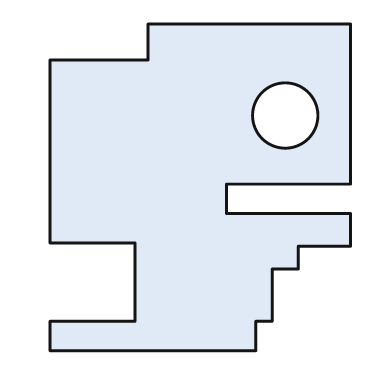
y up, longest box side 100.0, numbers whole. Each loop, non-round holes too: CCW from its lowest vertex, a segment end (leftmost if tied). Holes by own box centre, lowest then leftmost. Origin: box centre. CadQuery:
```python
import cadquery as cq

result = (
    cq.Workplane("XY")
    .moveTo(-46.0, -50.0)
    .lineTo(17.0, -50.0)
    .lineTo(17.0, -41.0)
    .lineTo(22.0, -41.0)
    .lineTo(22.0, -25.0)
    .lineTo(30.0, -25.0)
    .lineTo(30.0, -18.0)
    .lineTo(46.0, -18.0)
    .lineTo(46.0, -8.0)
    .lineTo(8.0, -8.0)
    .lineTo(8.0, 1.0)
    .lineTo(46.0, 1.0)
    .lineTo(46.0, 50.0)
    .lineTo(-16.0, 50.0)
    .lineTo(-16.0, 39.0)
    .lineTo(-46.0, 39.0)
    .lineTo(-46.0, -17.0)
    .lineTo(-20.0, -17.0)
    .lineTo(-20.0, -41.0)
    .lineTo(-46.0, -41.0)
    .close()
    .moveTo(26.0, 22.0)
    .circle(10.0)
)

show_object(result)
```